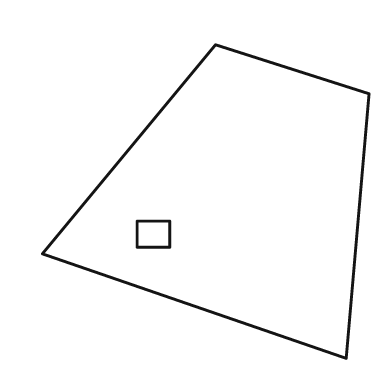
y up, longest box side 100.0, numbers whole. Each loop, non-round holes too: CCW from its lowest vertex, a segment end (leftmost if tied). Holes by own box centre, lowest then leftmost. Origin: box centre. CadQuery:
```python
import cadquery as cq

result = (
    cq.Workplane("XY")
    .moveTo(43.0, -48.0)
    .lineTo(50.0, 33.0)
    .lineTo(3.0, 48.0)
    .lineTo(-50.0, -16.0)
    .close()
    .moveTo(-21.0, -14.0)
    .lineTo(-11.0, -14.0)
    .lineTo(-11.0, -6.0)
    .lineTo(-21.0, -6.0)
    .close()
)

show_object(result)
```